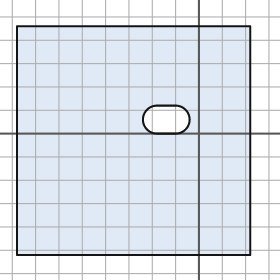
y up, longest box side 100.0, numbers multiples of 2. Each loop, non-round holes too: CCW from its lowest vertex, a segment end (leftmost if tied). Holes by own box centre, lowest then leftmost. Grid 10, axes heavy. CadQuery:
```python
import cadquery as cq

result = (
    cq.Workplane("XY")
    .moveTo(-78.0, -52.0)
    .lineTo(22.0, -52.0)
    .lineTo(22.0, 46.0)
    .lineTo(-78.0, 46.0)
    .close()
    .moveTo(-18.0, 0.0)
    .lineTo(-10.0, 0.0)
    .threePointArc((-4.0, 6.0), (-10.0, 12.0))
    .lineTo(-18.0, 12.0)
    .threePointArc((-24.0, 6.0), (-18.0, 0.0))
    .close()
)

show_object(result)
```